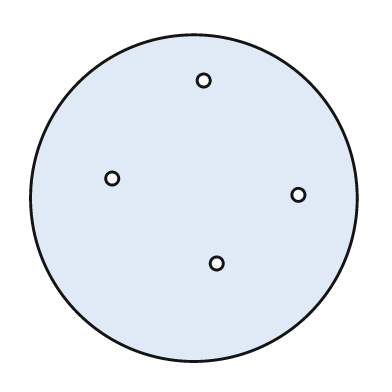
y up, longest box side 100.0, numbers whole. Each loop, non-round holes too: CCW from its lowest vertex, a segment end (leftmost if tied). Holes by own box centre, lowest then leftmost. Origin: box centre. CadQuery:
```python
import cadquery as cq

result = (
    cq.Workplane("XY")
    .moveTo(0.0, 0.0)
    .circle(50.0)
    .moveTo(7.0, -20.0)
    .circle(2.0)
    .moveTo(32.0, 1.0)
    .circle(2.0)
    .moveTo(-25.0, 6.0)
    .circle(2.0)
    .moveTo(3.0, 36.0)
    .circle(2.0)
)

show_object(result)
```